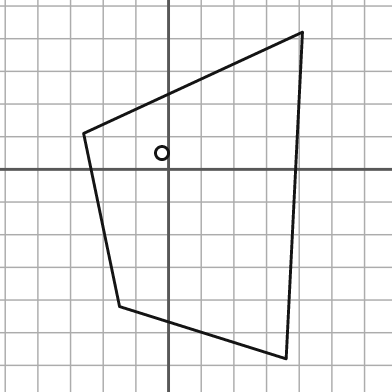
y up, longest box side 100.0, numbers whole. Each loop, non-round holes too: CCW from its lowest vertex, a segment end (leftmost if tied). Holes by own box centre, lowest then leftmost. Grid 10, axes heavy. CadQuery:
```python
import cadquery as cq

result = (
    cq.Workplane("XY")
    .moveTo(36.0, -58.0)
    .lineTo(41.0, 42.0)
    .lineTo(-26.0, 11.0)
    .lineTo(-15.0, -42.0)
    .close()
    .moveTo(-2.0, 5.0)
    .circle(2.0)
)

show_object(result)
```